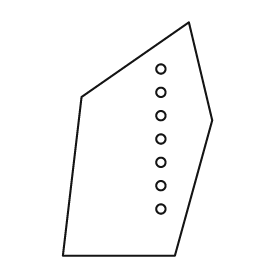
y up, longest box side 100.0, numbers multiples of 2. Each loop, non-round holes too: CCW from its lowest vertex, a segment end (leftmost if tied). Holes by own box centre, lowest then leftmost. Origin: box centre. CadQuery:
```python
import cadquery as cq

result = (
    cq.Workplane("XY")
    .moveTo(-32.0, -50.0)
    .lineTo(16.0, -50.0)
    .lineTo(32.0, 8.0)
    .lineTo(22.0, 50.0)
    .lineTo(-24.0, 18.0)
    .close()
    .moveTo(10.0, -30.0)
    .circle(2.0)
    .moveTo(10.0, -20.0)
    .circle(2.0)
    .moveTo(10.0, -10.0)
    .circle(2.0)
    .moveTo(10.0, 0.0)
    .circle(2.0)
    .moveTo(10.0, 10.0)
    .circle(2.0)
    .moveTo(10.0, 20.0)
    .circle(2.0)
    .moveTo(10.0, 30.0)
    .circle(2.0)
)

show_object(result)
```